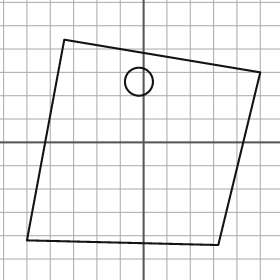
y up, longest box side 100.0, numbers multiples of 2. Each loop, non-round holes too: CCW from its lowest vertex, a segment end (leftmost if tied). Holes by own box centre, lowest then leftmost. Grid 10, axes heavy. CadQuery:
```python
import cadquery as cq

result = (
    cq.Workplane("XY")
    .moveTo(32.0, -44.0)
    .lineTo(50.0, 30.0)
    .lineTo(-34.0, 44.0)
    .lineTo(-50.0, -42.0)
    .close()
    .moveTo(-2.0, 26.0)
    .circle(6.0)
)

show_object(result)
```